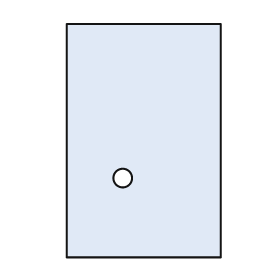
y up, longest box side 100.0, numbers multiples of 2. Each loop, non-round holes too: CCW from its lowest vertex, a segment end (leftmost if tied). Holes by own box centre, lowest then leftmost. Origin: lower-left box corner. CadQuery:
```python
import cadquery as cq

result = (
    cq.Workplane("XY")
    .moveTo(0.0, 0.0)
    .lineTo(66.0, 0.0)
    .lineTo(66.0, 100.0)
    .lineTo(0.0, 100.0)
    .close()
    .moveTo(24.0, 34.0)
    .circle(4.0)
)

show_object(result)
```